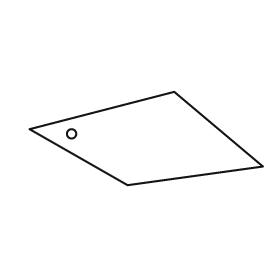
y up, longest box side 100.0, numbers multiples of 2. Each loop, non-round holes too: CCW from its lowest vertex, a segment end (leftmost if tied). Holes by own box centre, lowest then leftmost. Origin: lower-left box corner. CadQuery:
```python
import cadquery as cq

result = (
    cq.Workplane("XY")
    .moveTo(42.0, 0.0)
    .lineTo(100.0, 8.0)
    .lineTo(62.0, 40.0)
    .lineTo(0.0, 24.0)
    .close()
    .moveTo(18.0, 22.0)
    .circle(2.0)
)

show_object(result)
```